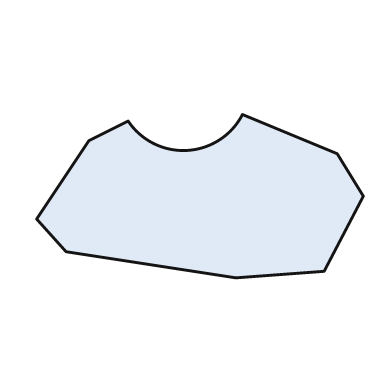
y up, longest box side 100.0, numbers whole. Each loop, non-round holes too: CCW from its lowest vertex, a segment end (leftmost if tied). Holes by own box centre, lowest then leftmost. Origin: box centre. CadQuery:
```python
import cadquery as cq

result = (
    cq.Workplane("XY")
    .moveTo(11.0, -25.0)
    .lineTo(38.0, -23.0)
    .lineTo(50.0, 0.0)
    .lineTo(42.0, 13.0)
    .lineTo(13.0, 25.0)
    .threePointArc((-4.0, 14.0), (-22.0, 23.0))
    .lineTo(-34.0, 17.0)
    .lineTo(-50.0, -7.0)
    .lineTo(-41.0, -17.0)
    .close()
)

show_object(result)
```